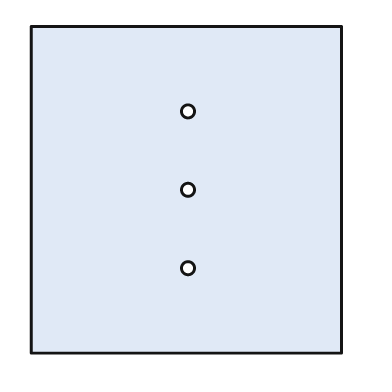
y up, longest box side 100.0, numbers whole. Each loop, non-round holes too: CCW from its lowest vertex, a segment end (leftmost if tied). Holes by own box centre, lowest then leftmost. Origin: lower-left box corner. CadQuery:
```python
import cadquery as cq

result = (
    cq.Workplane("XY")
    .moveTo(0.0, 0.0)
    .lineTo(95.0, 0.0)
    .lineTo(95.0, 100.0)
    .lineTo(0.0, 100.0)
    .close()
    .moveTo(48.0, 26.0)
    .circle(2.0)
    .moveTo(48.0, 50.0)
    .circle(2.0)
    .moveTo(48.0, 74.0)
    .circle(2.0)
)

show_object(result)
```